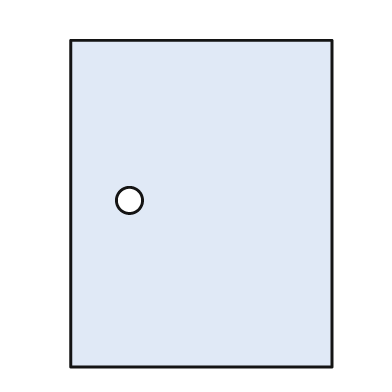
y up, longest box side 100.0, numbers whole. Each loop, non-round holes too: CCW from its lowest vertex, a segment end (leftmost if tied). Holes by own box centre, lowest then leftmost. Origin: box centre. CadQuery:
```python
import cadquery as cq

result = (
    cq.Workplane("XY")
    .moveTo(-40.0, -50.0)
    .lineTo(40.0, -50.0)
    .lineTo(40.0, 50.0)
    .lineTo(-40.0, 50.0)
    .close()
    .moveTo(-22.0, 1.0)
    .circle(4.0)
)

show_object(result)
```